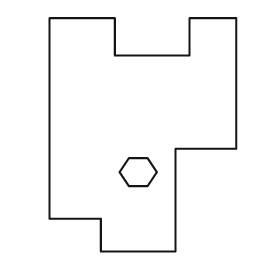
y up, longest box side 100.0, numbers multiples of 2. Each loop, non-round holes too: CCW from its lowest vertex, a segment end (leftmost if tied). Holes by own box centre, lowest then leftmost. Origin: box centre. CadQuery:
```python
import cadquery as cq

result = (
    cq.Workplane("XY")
    .moveTo(-18.0, -50.0)
    .lineTo(14.0, -50.0)
    .lineTo(14.0, -6.0)
    .lineTo(40.0, -6.0)
    .lineTo(40.0, 50.0)
    .lineTo(20.0, 50.0)
    .lineTo(20.0, 34.0)
    .lineTo(-12.0, 34.0)
    .lineTo(-12.0, 50.0)
    .lineTo(-40.0, 50.0)
    .lineTo(-40.0, -36.0)
    .lineTo(-18.0, -36.0)
    .close()
    .moveTo(-6.0, -22.0)
    .lineTo(2.0, -22.0)
    .lineTo(6.0, -16.0)
    .lineTo(2.0, -10.0)
    .lineTo(-6.0, -10.0)
    .lineTo(-10.0, -16.0)
    .close()
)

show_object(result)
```